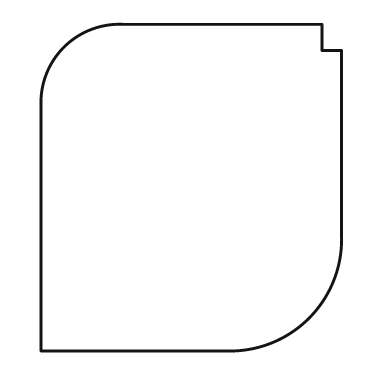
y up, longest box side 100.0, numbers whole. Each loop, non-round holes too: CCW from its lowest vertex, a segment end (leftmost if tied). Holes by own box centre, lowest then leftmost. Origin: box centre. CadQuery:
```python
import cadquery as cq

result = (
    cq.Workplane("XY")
    .moveTo(-46.0, -50.0)
    .lineTo(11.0, -50.0)
    .threePointArc((36.0, -40.0), (46.0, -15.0))
    .lineTo(46.0, 42.0)
    .lineTo(40.0, 42.0)
    .lineTo(40.0, 50.0)
    .lineTo(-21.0, 50.0)
    .threePointArc((-39.0, 43.0), (-46.0, 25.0))
    .close()
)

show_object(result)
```